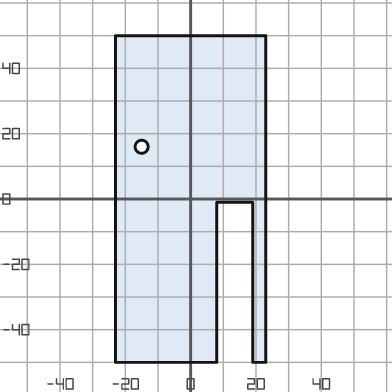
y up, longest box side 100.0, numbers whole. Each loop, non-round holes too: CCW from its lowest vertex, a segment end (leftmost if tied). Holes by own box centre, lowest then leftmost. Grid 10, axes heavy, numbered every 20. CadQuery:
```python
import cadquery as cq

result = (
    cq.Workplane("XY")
    .moveTo(-23.0, -50.0)
    .lineTo(8.0, -50.0)
    .lineTo(8.0, -1.0)
    .lineTo(19.0, -1.0)
    .lineTo(19.0, -50.0)
    .lineTo(23.0, -50.0)
    .lineTo(23.0, 50.0)
    .lineTo(-23.0, 50.0)
    .close()
    .moveTo(-15.0, 16.0)
    .circle(2.0)
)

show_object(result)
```